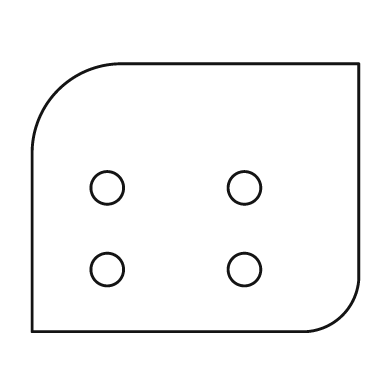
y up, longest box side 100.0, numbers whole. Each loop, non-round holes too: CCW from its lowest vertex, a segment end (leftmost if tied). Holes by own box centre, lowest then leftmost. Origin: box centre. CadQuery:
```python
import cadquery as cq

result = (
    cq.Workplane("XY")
    .moveTo(-50.0, -41.0)
    .lineTo(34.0, -41.0)
    .threePointArc((45.0, -36.0), (50.0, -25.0))
    .lineTo(50.0, 41.0)
    .lineTo(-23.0, 41.0)
    .threePointArc((-42.0, 33.0), (-50.0, 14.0))
    .close()
    .moveTo(-27.0, -22.0)
    .circle(5.0)
    .moveTo(15.0, -22.0)
    .circle(5.0)
    .moveTo(-27.0, 3.0)
    .circle(5.0)
    .moveTo(15.0, 3.0)
    .circle(5.0)
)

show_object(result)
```